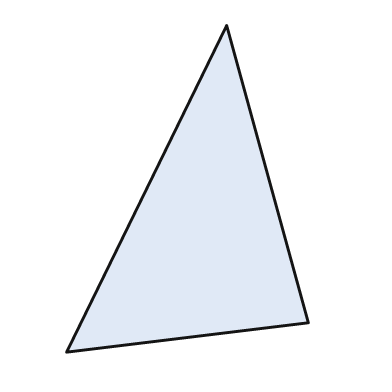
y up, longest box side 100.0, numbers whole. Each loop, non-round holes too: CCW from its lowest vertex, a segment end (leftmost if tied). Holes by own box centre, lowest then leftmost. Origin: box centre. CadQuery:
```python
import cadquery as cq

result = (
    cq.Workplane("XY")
    .moveTo(-37.0, -50.0)
    .lineTo(37.0, -41.0)
    .lineTo(12.0, 50.0)
    .close()
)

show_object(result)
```